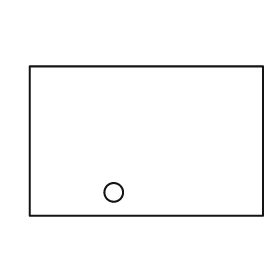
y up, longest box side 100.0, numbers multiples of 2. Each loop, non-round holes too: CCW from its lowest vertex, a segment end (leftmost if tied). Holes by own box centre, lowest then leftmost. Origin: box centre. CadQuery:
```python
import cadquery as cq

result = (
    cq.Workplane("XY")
    .moveTo(-50.0, -32.0)
    .lineTo(50.0, -32.0)
    .lineTo(50.0, 32.0)
    .lineTo(-50.0, 32.0)
    .close()
    .moveTo(-14.0, -22.0)
    .circle(4.0)
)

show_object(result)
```